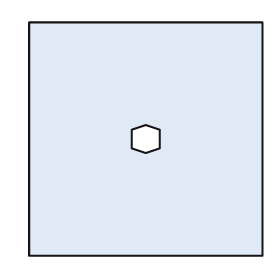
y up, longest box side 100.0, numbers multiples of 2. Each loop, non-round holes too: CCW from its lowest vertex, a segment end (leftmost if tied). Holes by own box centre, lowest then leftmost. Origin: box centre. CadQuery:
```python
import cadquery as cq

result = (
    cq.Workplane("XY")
    .moveTo(-50.0, -50.0)
    .lineTo(50.0, -50.0)
    .lineTo(50.0, 50.0)
    .lineTo(-50.0, 50.0)
    .close()
    .moveTo(0.0, -6.0)
    .lineTo(6.0, -4.0)
    .lineTo(6.0, 4.0)
    .lineTo(0.0, 6.0)
    .lineTo(-6.0, 4.0)
    .lineTo(-6.0, -4.0)
    .close()
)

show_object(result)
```